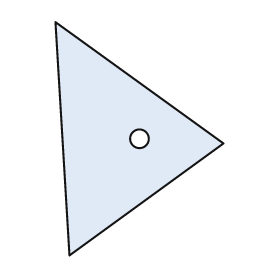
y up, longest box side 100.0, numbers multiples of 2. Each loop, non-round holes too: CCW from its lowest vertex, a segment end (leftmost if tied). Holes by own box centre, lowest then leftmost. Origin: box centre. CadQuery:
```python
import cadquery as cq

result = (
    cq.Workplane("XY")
    .moveTo(-30.0, -50.0)
    .lineTo(36.0, -2.0)
    .lineTo(-36.0, 50.0)
    .close()
    .moveTo(0.0, 0.0)
    .circle(4.0)
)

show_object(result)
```